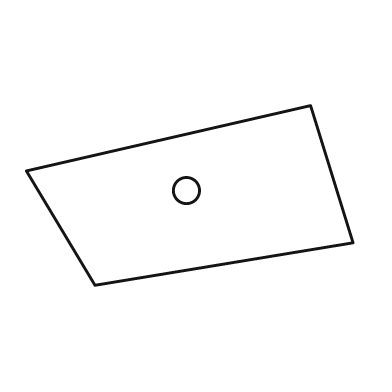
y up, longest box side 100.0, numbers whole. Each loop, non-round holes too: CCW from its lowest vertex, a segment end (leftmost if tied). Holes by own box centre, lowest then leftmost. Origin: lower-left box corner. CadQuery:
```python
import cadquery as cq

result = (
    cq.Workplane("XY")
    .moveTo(21.0, 0.0)
    .lineTo(100.0, 13.0)
    .lineTo(87.0, 55.0)
    .lineTo(0.0, 35.0)
    .close()
    .moveTo(49.0, 29.0)
    .circle(4.0)
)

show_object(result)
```